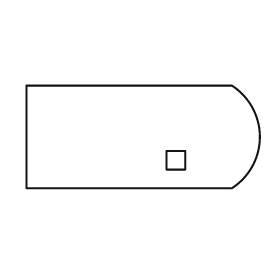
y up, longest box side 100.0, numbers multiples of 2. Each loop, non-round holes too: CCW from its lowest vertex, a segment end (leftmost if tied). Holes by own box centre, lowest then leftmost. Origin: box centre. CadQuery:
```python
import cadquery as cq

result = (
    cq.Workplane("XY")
    .moveTo(-50.0, -22.0)
    .lineTo(38.0, -22.0)
    .threePointArc((50.0, 0.0), (38.0, 22.0))
    .lineTo(-50.0, 22.0)
    .close()
    .moveTo(10.0, -14.0)
    .lineTo(18.0, -14.0)
    .lineTo(18.0, -6.0)
    .lineTo(10.0, -6.0)
    .close()
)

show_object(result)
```